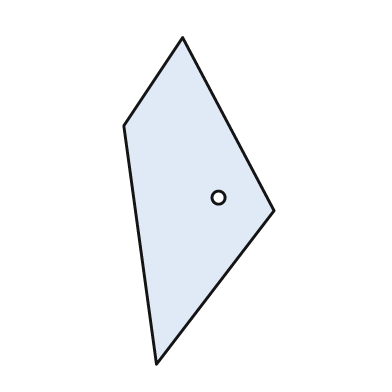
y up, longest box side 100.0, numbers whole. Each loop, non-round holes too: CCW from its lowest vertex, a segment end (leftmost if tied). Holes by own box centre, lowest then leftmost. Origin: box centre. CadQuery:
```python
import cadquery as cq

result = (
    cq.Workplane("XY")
    .moveTo(-13.0, -50.0)
    .lineTo(23.0, -3.0)
    .lineTo(-5.0, 50.0)
    .lineTo(-23.0, 23.0)
    .close()
    .moveTo(6.0, 1.0)
    .circle(2.0)
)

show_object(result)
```